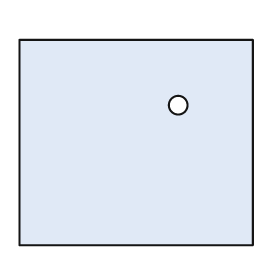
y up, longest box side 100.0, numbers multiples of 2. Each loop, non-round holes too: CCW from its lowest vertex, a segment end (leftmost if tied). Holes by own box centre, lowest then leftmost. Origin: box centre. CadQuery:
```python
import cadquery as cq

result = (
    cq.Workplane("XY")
    .moveTo(-50.0, -44.0)
    .lineTo(50.0, -44.0)
    .lineTo(50.0, 44.0)
    .lineTo(-50.0, 44.0)
    .close()
    .moveTo(18.0, 16.0)
    .circle(4.0)
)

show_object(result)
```